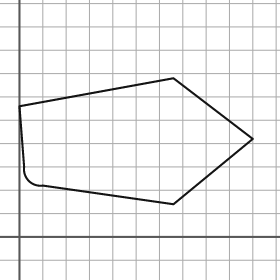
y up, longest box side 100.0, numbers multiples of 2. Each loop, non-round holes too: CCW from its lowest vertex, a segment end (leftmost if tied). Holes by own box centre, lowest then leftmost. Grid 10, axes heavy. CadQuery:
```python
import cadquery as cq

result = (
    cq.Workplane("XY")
    .moveTo(66.0, 14.0)
    .lineTo(100.0, 42.0)
    .lineTo(66.0, 68.0)
    .lineTo(0.0, 56.0)
    .lineTo(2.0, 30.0)
    .threePointArc((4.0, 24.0), (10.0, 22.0))
    .close()
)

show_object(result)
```